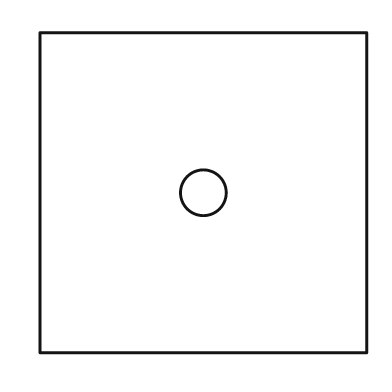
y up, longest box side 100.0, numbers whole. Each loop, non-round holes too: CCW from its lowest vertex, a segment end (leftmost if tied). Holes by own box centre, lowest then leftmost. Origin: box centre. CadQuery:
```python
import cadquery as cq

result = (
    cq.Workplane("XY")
    .moveTo(-50.0, -49.0)
    .lineTo(50.0, -49.0)
    .lineTo(50.0, 49.0)
    .lineTo(-50.0, 49.0)
    .close()
    .moveTo(0.0, 0.0)
    .circle(7.0)
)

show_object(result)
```